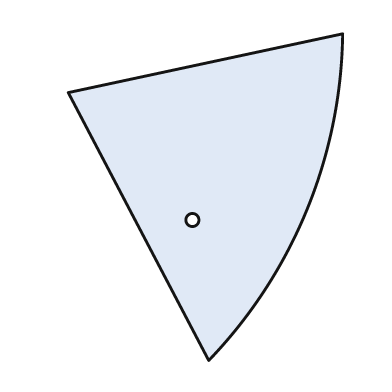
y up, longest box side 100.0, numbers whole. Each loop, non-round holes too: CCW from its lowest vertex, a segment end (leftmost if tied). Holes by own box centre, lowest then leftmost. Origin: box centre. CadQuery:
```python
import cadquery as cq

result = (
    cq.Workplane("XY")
    .moveTo(1.0, -50.0)
    .threePointArc((31.0, -4.0), (42.0, 50.0))
    .lineTo(-42.0, 32.0)
    .close()
    .moveTo(-4.0, -7.0)
    .circle(2.0)
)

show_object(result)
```